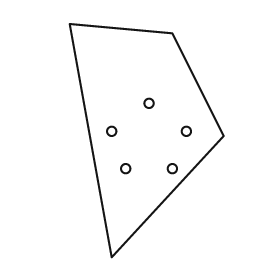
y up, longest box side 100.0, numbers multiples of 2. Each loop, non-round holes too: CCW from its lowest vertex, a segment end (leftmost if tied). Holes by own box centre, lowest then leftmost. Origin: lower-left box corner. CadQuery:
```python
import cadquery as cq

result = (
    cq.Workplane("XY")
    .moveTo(18.0, 0.0)
    .lineTo(66.0, 52.0)
    .lineTo(44.0, 96.0)
    .lineTo(0.0, 100.0)
    .close()
    .moveTo(24.0, 38.0)
    .circle(2.0)
    .moveTo(44.0, 38.0)
    .circle(2.0)
    .moveTo(18.0, 54.0)
    .circle(2.0)
    .moveTo(50.0, 54.0)
    .circle(2.0)
    .moveTo(34.0, 66.0)
    .circle(2.0)
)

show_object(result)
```